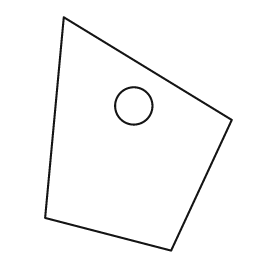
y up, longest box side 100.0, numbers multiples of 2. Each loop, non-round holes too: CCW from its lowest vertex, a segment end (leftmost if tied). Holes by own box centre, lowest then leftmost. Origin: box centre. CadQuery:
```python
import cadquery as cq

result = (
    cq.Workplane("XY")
    .moveTo(14.0, -50.0)
    .lineTo(40.0, 6.0)
    .lineTo(-32.0, 50.0)
    .lineTo(-40.0, -36.0)
    .close()
    .moveTo(-2.0, 12.0)
    .circle(8.0)
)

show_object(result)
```